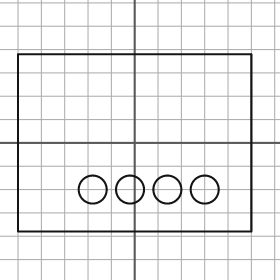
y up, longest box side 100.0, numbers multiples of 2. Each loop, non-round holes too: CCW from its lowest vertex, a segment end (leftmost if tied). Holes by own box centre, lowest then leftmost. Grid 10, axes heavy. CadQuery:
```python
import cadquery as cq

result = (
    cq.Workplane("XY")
    .moveTo(-50.0, -38.0)
    .lineTo(50.0, -38.0)
    .lineTo(50.0, 38.0)
    .lineTo(-50.0, 38.0)
    .close()
    .moveTo(-18.0, -20.0)
    .circle(6.0)
    .moveTo(-2.0, -20.0)
    .circle(6.0)
    .moveTo(14.0, -20.0)
    .circle(6.0)
    .moveTo(30.0, -20.0)
    .circle(6.0)
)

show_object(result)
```